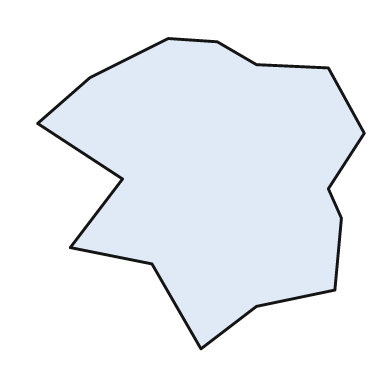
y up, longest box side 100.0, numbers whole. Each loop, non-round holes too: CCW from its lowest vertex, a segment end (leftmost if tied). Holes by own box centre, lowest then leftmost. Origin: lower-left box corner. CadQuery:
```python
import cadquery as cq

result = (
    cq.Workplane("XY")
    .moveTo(50.0, 0.0)
    .lineTo(67.0, 13.0)
    .lineTo(91.0, 18.0)
    .lineTo(93.0, 40.0)
    .lineTo(89.0, 49.0)
    .lineTo(100.0, 66.0)
    .lineTo(89.0, 86.0)
    .lineTo(67.0, 87.0)
    .lineTo(55.0, 94.0)
    .lineTo(40.0, 95.0)
    .lineTo(16.0, 83.0)
    .lineTo(0.0, 69.0)
    .lineTo(26.0, 52.0)
    .lineTo(10.0, 31.0)
    .lineTo(35.0, 26.0)
    .close()
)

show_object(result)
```